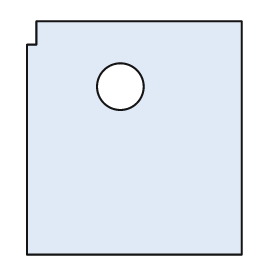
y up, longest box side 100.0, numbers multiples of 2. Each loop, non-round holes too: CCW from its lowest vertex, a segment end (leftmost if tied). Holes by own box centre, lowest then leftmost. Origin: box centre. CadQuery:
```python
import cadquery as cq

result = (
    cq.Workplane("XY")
    .moveTo(-46.0, -50.0)
    .lineTo(46.0, -50.0)
    .lineTo(46.0, 50.0)
    .lineTo(-42.0, 50.0)
    .lineTo(-42.0, 40.0)
    .lineTo(-46.0, 40.0)
    .close()
    .moveTo(-6.0, 22.0)
    .circle(10.0)
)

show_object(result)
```